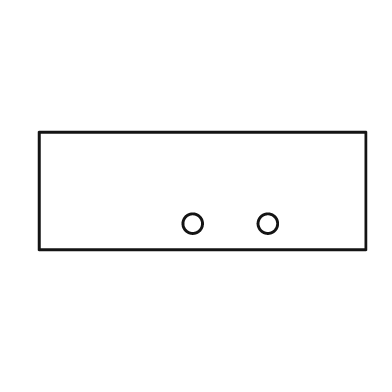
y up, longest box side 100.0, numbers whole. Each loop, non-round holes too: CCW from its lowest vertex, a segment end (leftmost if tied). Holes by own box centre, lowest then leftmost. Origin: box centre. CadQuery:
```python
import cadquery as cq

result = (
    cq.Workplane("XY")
    .moveTo(-50.0, -18.0)
    .lineTo(50.0, -18.0)
    .lineTo(50.0, 18.0)
    .lineTo(-50.0, 18.0)
    .close()
    .moveTo(-3.0, -10.0)
    .circle(3.0)
    .moveTo(20.0, -10.0)
    .circle(3.0)
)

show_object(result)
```